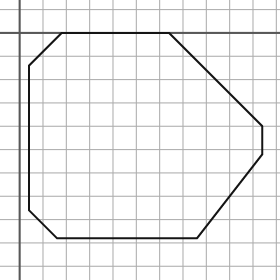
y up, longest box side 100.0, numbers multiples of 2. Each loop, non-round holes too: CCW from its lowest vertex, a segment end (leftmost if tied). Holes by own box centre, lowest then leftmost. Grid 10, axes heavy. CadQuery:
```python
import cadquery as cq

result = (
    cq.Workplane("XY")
    .moveTo(16.0, -88.0)
    .lineTo(76.0, -88.0)
    .lineTo(104.0, -52.0)
    .lineTo(104.0, -40.0)
    .lineTo(64.0, 0.0)
    .lineTo(18.0, 0.0)
    .lineTo(4.0, -14.0)
    .lineTo(4.0, -76.0)
    .close()
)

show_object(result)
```